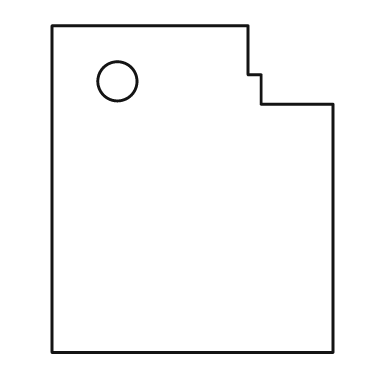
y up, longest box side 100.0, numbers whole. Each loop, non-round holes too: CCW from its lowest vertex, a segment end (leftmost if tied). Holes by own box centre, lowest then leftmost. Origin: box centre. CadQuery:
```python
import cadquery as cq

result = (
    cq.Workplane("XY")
    .moveTo(-43.0, -50.0)
    .lineTo(43.0, -50.0)
    .lineTo(43.0, 26.0)
    .lineTo(21.0, 26.0)
    .lineTo(21.0, 35.0)
    .lineTo(17.0, 35.0)
    .lineTo(17.0, 50.0)
    .lineTo(-43.0, 50.0)
    .close()
    .moveTo(-23.0, 33.0)
    .circle(6.0)
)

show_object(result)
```